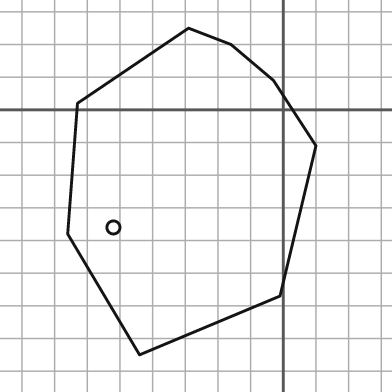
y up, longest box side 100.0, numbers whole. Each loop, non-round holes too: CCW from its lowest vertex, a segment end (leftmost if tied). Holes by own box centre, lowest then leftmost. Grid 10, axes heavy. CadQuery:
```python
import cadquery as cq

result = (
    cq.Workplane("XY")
    .moveTo(-44.0, -75.0)
    .lineTo(-1.0, -57.0)
    .lineTo(10.0, -11.0)
    .lineTo(-3.0, 9.0)
    .lineTo(-16.0, 20.0)
    .lineTo(-29.0, 25.0)
    .lineTo(-63.0, 2.0)
    .lineTo(-66.0, -38.0)
    .close()
    .moveTo(-52.0, -36.0)
    .circle(2.0)
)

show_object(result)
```